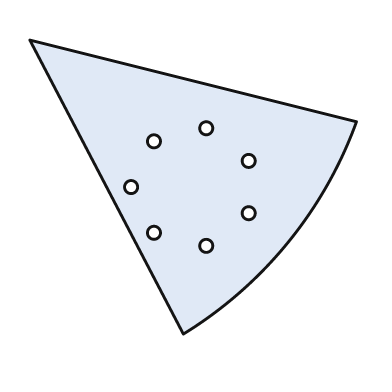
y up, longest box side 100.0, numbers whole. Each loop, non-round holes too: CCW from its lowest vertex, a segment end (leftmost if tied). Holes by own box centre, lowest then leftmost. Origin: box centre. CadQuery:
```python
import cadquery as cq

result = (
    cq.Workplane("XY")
    .moveTo(-3.0, -45.0)
    .threePointArc((29.0, -17.0), (50.0, 20.0))
    .lineTo(-50.0, 45.0)
    .close()
    .moveTo(4.0, -18.0)
    .circle(2.0)
    .moveTo(-12.0, -14.0)
    .circle(2.0)
    .moveTo(17.0, -8.0)
    .circle(2.0)
    .moveTo(-19.0, 0.0)
    .circle(2.0)
    .moveTo(17.0, 8.0)
    .circle(2.0)
    .moveTo(-12.0, 14.0)
    .circle(2.0)
    .moveTo(4.0, 18.0)
    .circle(2.0)
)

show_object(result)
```